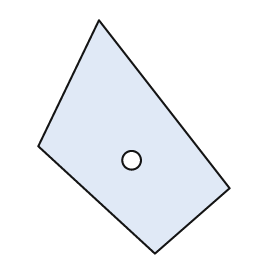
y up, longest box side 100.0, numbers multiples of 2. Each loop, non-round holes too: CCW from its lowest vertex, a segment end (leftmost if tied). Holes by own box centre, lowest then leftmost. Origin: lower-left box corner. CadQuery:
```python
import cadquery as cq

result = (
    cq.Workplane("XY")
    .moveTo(50.0, 0.0)
    .lineTo(82.0, 28.0)
    .lineTo(26.0, 100.0)
    .lineTo(0.0, 46.0)
    .close()
    .moveTo(40.0, 40.0)
    .circle(4.0)
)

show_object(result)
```